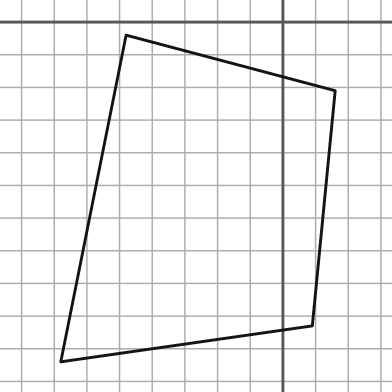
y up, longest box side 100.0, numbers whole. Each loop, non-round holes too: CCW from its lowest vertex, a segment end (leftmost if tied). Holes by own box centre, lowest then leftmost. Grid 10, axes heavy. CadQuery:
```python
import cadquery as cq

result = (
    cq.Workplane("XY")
    .moveTo(-68.0, -104.0)
    .lineTo(9.0, -93.0)
    .lineTo(16.0, -21.0)
    .lineTo(-48.0, -4.0)
    .close()
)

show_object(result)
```